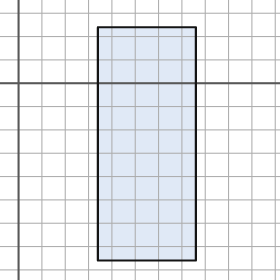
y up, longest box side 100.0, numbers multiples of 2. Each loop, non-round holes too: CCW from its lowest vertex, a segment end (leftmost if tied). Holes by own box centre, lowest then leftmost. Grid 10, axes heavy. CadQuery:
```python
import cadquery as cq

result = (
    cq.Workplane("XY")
    .moveTo(34.0, -76.0)
    .lineTo(76.0, -76.0)
    .lineTo(76.0, 24.0)
    .lineTo(34.0, 24.0)
    .close()
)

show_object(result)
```